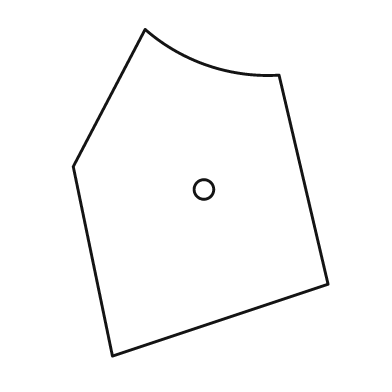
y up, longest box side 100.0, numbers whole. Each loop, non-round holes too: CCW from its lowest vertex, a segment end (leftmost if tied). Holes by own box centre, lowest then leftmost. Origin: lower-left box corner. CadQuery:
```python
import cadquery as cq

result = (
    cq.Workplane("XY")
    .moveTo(12.0, 0.0)
    .lineTo(78.0, 22.0)
    .lineTo(63.0, 86.0)
    .threePointArc((41.0, 89.0), (22.0, 100.0))
    .lineTo(0.0, 58.0)
    .close()
    .moveTo(40.0, 51.0)
    .circle(3.0)
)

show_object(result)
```